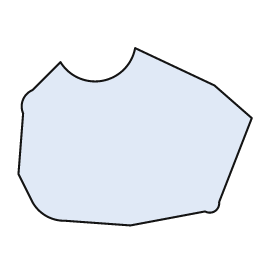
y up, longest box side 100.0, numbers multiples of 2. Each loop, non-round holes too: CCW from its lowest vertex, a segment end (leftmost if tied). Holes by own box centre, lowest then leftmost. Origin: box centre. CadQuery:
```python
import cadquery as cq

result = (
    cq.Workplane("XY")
    .moveTo(-2.0, -38.0)
    .lineTo(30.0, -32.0)
    .threePointArc((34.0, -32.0), (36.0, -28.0))
    .lineTo(50.0, 8.0)
    .lineTo(34.0, 22.0)
    .lineTo(0.0, 38.0)
    .threePointArc((-14.0, 24.0), (-32.0, 32.0))
    .lineTo(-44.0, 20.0)
    .threePointArc((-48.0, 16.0), (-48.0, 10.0))
    .lineTo(-50.0, -16.0)
    .lineTo(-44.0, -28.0)
    .threePointArc((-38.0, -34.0), (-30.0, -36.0))
    .close()
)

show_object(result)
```